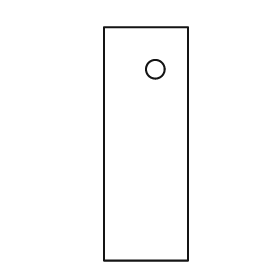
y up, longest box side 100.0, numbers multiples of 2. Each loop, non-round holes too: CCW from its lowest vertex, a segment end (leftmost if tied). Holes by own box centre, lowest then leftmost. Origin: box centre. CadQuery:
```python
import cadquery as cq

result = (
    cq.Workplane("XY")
    .moveTo(-18.0, -50.0)
    .lineTo(18.0, -50.0)
    .lineTo(18.0, 50.0)
    .lineTo(-18.0, 50.0)
    .close()
    .moveTo(4.0, 32.0)
    .circle(4.0)
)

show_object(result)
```